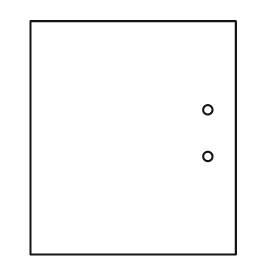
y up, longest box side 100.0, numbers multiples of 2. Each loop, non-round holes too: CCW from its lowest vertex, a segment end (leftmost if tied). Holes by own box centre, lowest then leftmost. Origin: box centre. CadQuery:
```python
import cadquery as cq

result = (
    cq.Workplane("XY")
    .moveTo(-44.0, -50.0)
    .lineTo(44.0, -50.0)
    .lineTo(44.0, 50.0)
    .lineTo(-44.0, 50.0)
    .close()
    .moveTo(32.0, -8.0)
    .circle(2.0)
    .moveTo(32.0, 12.0)
    .circle(2.0)
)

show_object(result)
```